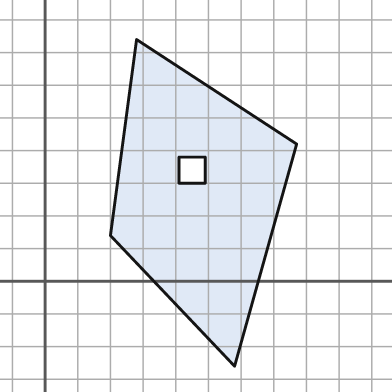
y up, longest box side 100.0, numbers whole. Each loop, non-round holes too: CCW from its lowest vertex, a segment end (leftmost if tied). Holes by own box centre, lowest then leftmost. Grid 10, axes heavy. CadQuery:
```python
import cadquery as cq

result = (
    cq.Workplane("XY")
    .moveTo(58.0, -26.0)
    .lineTo(77.0, 42.0)
    .lineTo(28.0, 74.0)
    .lineTo(20.0, 14.0)
    .close()
    .moveTo(41.0, 30.0)
    .lineTo(49.0, 30.0)
    .lineTo(49.0, 38.0)
    .lineTo(41.0, 38.0)
    .close()
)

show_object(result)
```